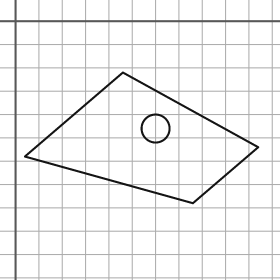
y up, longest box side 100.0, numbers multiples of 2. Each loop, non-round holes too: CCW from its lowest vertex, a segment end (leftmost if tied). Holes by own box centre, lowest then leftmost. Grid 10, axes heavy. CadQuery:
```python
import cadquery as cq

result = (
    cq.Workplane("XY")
    .moveTo(76.0, -78.0)
    .lineTo(104.0, -54.0)
    .lineTo(46.0, -22.0)
    .lineTo(4.0, -58.0)
    .close()
    .moveTo(60.0, -46.0)
    .circle(6.0)
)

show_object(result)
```